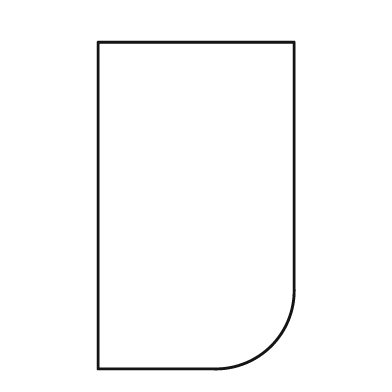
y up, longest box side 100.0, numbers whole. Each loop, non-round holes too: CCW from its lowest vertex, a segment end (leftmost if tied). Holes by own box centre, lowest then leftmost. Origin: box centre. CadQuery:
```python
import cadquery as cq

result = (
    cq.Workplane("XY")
    .moveTo(-30.0, -50.0)
    .lineTo(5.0, -50.0)
    .threePointArc((23.0, -43.0), (30.0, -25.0))
    .lineTo(30.0, 50.0)
    .lineTo(-30.0, 50.0)
    .close()
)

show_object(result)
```